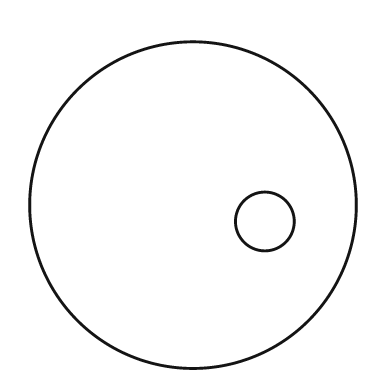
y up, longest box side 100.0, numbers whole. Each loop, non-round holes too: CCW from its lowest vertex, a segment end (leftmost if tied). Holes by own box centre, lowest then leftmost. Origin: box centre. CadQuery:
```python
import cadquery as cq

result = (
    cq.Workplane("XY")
    .moveTo(0.0, 0.0)
    .circle(50.0)
    .moveTo(22.0, -5.0)
    .circle(9.0)
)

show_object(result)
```